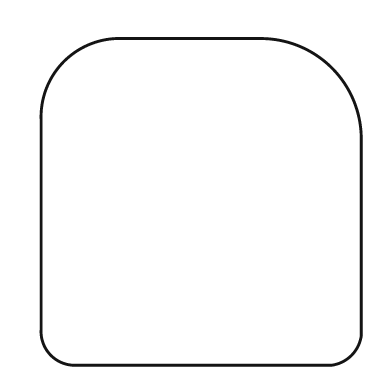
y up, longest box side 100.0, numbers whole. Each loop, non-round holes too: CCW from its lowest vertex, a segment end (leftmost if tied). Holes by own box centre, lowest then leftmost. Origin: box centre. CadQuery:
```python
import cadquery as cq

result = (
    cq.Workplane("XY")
    .moveTo(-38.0, -50.0)
    .lineTo(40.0, -50.0)
    .threePointArc((46.0, -47.0), (49.0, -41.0))
    .lineTo(49.0, 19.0)
    .threePointArc((40.0, 41.0), (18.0, 50.0))
    .lineTo(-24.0, 50.0)
    .threePointArc((-42.0, 43.0), (-49.0, 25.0))
    .lineTo(-49.0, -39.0)
    .threePointArc((-46.0, -47.0), (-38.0, -50.0))
    .close()
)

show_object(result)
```